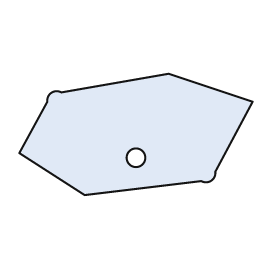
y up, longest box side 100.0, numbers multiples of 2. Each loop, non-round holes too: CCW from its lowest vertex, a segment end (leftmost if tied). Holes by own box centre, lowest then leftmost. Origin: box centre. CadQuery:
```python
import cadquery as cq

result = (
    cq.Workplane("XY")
    .moveTo(-22.0, -26.0)
    .lineTo(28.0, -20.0)
    .threePointArc((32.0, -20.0), (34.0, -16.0))
    .lineTo(50.0, 14.0)
    .lineTo(14.0, 26.0)
    .lineTo(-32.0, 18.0)
    .threePointArc((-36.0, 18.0), (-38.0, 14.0))
    .lineTo(-50.0, -8.0)
    .close()
    .moveTo(0.0, -10.0)
    .circle(4.0)
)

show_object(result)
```